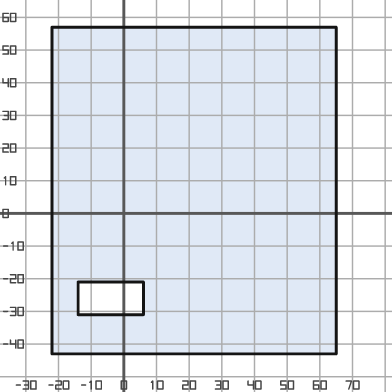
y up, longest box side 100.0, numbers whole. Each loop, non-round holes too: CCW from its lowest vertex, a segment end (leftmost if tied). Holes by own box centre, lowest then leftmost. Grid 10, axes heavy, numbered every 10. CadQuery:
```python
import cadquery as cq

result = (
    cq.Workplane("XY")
    .moveTo(-22.0, -43.0)
    .lineTo(65.0, -43.0)
    .lineTo(65.0, 57.0)
    .lineTo(-22.0, 57.0)
    .close()
    .moveTo(-14.0, -31.0)
    .lineTo(6.0, -31.0)
    .lineTo(6.0, -21.0)
    .lineTo(-14.0, -21.0)
    .close()
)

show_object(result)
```